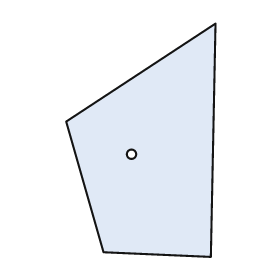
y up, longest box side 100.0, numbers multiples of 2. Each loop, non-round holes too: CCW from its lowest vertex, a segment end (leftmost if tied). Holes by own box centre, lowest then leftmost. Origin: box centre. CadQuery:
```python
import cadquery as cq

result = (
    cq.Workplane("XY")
    .moveTo(30.0, -50.0)
    .lineTo(32.0, 50.0)
    .lineTo(-32.0, 8.0)
    .lineTo(-16.0, -48.0)
    .close()
    .moveTo(-4.0, -6.0)
    .circle(2.0)
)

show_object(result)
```